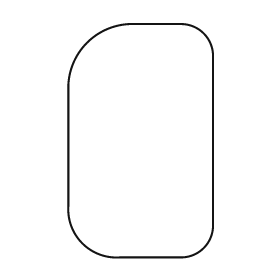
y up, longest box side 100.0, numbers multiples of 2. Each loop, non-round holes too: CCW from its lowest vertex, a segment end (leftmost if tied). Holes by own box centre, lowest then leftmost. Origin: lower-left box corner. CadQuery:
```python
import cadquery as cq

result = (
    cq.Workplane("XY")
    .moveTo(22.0, 0.0)
    .lineTo(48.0, 0.0)
    .threePointArc((58.0, 4.0), (62.0, 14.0))
    .lineTo(62.0, 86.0)
    .threePointArc((58.0, 96.0), (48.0, 100.0))
    .lineTo(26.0, 100.0)
    .threePointArc((8.0, 92.0), (0.0, 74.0))
    .lineTo(0.0, 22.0)
    .threePointArc((6.0, 6.0), (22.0, 0.0))
    .close()
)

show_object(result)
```